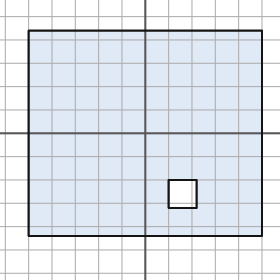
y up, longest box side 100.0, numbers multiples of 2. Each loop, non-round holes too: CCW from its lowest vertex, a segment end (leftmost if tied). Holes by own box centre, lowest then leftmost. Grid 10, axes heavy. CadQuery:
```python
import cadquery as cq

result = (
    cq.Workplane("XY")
    .moveTo(-50.0, -44.0)
    .lineTo(50.0, -44.0)
    .lineTo(50.0, 44.0)
    .lineTo(-50.0, 44.0)
    .close()
    .moveTo(10.0, -32.0)
    .lineTo(22.0, -32.0)
    .lineTo(22.0, -20.0)
    .lineTo(10.0, -20.0)
    .close()
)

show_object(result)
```